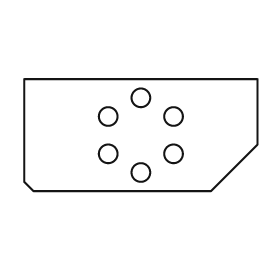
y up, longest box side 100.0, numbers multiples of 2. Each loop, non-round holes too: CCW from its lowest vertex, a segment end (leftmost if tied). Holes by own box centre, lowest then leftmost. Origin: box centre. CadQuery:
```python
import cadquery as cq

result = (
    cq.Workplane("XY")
    .moveTo(-46.0, -24.0)
    .lineTo(30.0, -24.0)
    .lineTo(50.0, -4.0)
    .lineTo(50.0, 24.0)
    .lineTo(-50.0, 24.0)
    .lineTo(-50.0, -20.0)
    .close()
    .moveTo(0.0, -16.0)
    .circle(4.0)
    .moveTo(-14.0, -8.0)
    .circle(4.0)
    .moveTo(14.0, -8.0)
    .circle(4.0)
    .moveTo(-14.0, 8.0)
    .circle(4.0)
    .moveTo(14.0, 8.0)
    .circle(4.0)
    .moveTo(0.0, 16.0)
    .circle(4.0)
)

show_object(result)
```